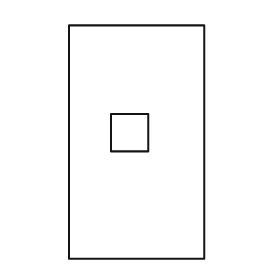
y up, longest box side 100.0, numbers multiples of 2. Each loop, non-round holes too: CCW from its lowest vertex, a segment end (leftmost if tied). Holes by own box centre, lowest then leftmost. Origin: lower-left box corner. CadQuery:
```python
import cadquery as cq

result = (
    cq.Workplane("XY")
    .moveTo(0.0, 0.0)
    .lineTo(58.0, 0.0)
    .lineTo(58.0, 100.0)
    .lineTo(0.0, 100.0)
    .close()
    .moveTo(18.0, 46.0)
    .lineTo(34.0, 46.0)
    .lineTo(34.0, 62.0)
    .lineTo(18.0, 62.0)
    .close()
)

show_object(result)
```